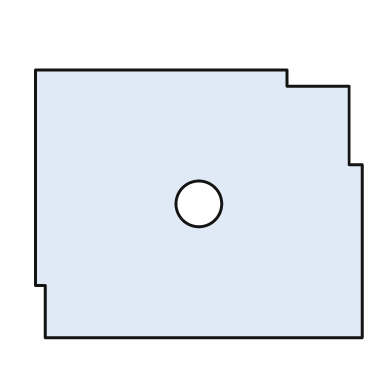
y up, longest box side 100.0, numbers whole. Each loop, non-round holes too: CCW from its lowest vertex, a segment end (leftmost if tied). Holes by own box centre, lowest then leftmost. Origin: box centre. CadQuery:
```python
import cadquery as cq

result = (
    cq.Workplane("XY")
    .moveTo(-47.0, -41.0)
    .lineTo(50.0, -41.0)
    .lineTo(50.0, 12.0)
    .lineTo(46.0, 12.0)
    .lineTo(46.0, 36.0)
    .lineTo(27.0, 36.0)
    .lineTo(27.0, 41.0)
    .lineTo(-50.0, 41.0)
    .lineTo(-50.0, -25.0)
    .lineTo(-47.0, -25.0)
    .close()
    .moveTo(0.0, 0.0)
    .circle(7.0)
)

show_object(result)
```